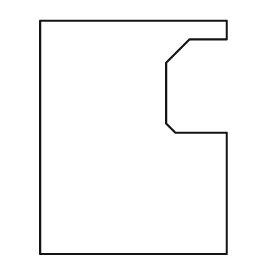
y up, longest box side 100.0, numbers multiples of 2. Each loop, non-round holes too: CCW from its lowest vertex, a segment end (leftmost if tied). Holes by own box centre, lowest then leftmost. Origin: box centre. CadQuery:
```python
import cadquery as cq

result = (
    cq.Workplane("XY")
    .moveTo(-40.0, -50.0)
    .lineTo(40.0, -50.0)
    .lineTo(40.0, 2.0)
    .lineTo(18.0, 2.0)
    .lineTo(14.0, 6.0)
    .lineTo(14.0, 32.0)
    .lineTo(24.0, 42.0)
    .lineTo(40.0, 42.0)
    .lineTo(40.0, 50.0)
    .lineTo(-40.0, 50.0)
    .close()
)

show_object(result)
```